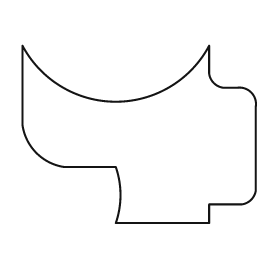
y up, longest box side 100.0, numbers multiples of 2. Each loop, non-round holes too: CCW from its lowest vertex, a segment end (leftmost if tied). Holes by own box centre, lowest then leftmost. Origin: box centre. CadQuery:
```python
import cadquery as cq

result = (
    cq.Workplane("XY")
    .moveTo(-10.0, -38.0)
    .lineTo(30.0, -38.0)
    .lineTo(30.0, -30.0)
    .lineTo(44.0, -30.0)
    .threePointArc((48.0, -28.0), (50.0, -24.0))
    .lineTo(50.0, 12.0)
    .threePointArc((48.0, 18.0), (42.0, 20.0))
    .lineTo(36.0, 20.0)
    .threePointArc((32.0, 22.0), (30.0, 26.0))
    .lineTo(30.0, 38.0)
    .threePointArc((-10.0, 14.0), (-50.0, 38.0))
    .lineTo(-50.0, 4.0)
    .threePointArc((-44.0, -8.0), (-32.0, -14.0))
    .lineTo(-10.0, -14.0)
    .threePointArc((-8.0, -26.0), (-10.0, -38.0))
    .close()
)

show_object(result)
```